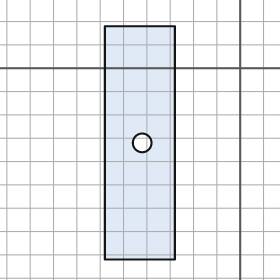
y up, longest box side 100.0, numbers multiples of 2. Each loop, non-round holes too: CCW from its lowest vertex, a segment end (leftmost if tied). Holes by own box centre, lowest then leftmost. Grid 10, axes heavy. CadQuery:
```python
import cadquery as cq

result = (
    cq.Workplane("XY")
    .moveTo(-58.0, -82.0)
    .lineTo(-28.0, -82.0)
    .lineTo(-28.0, 18.0)
    .lineTo(-58.0, 18.0)
    .close()
    .moveTo(-42.0, -32.0)
    .circle(4.0)
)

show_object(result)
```